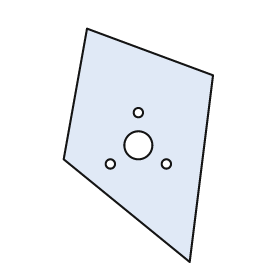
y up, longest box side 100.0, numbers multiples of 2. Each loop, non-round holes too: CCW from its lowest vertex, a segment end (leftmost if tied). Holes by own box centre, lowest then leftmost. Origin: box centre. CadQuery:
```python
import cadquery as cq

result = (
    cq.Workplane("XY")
    .moveTo(22.0, -50.0)
    .lineTo(32.0, 30.0)
    .lineTo(-22.0, 50.0)
    .lineTo(-32.0, -6.0)
    .close()
    .moveTo(-12.0, -8.0)
    .circle(2.0)
    .moveTo(12.0, -8.0)
    .circle(2.0)
    .moveTo(0.0, 0.0)
    .circle(6.0)
    .moveTo(0.0, 14.0)
    .circle(2.0)
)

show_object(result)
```